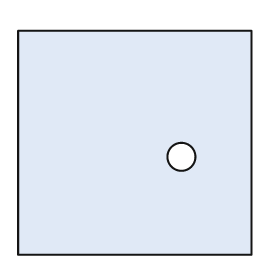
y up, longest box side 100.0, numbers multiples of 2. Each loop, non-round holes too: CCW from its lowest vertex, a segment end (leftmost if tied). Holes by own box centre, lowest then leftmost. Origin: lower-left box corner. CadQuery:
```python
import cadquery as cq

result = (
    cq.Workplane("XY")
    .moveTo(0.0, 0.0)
    .lineTo(100.0, 0.0)
    .lineTo(100.0, 96.0)
    .lineTo(0.0, 96.0)
    .close()
    .moveTo(70.0, 42.0)
    .circle(6.0)
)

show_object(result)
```